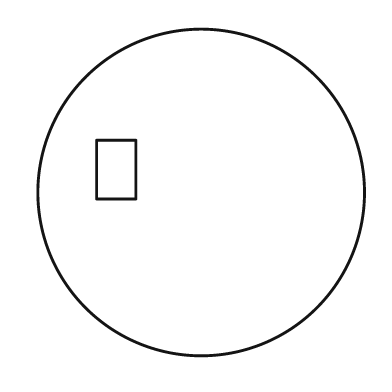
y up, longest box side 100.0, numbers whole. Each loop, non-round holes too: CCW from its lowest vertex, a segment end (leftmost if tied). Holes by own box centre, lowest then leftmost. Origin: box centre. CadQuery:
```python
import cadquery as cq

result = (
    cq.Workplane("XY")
    .moveTo(0.0, 0.0)
    .circle(50.0)
    .moveTo(-32.0, -2.0)
    .lineTo(-20.0, -2.0)
    .lineTo(-20.0, 16.0)
    .lineTo(-32.0, 16.0)
    .close()
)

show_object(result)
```